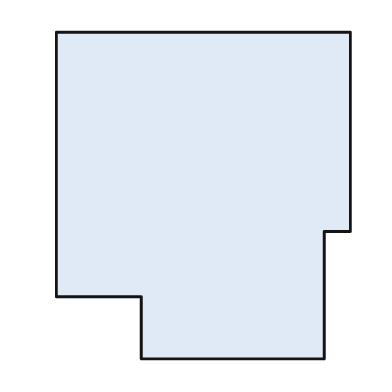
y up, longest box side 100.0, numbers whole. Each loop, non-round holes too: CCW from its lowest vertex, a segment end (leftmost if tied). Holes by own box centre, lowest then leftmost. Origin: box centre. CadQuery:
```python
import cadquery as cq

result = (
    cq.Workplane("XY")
    .moveTo(-19.0, -50.0)
    .lineTo(37.0, -50.0)
    .lineTo(37.0, -11.0)
    .lineTo(45.0, -11.0)
    .lineTo(45.0, 50.0)
    .lineTo(-45.0, 50.0)
    .lineTo(-45.0, -31.0)
    .lineTo(-19.0, -31.0)
    .close()
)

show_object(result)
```